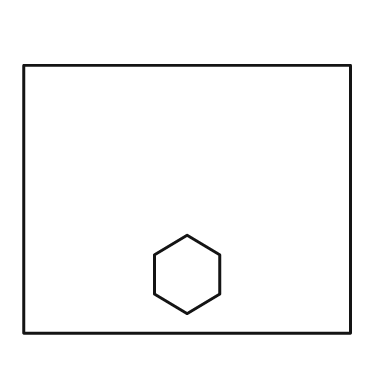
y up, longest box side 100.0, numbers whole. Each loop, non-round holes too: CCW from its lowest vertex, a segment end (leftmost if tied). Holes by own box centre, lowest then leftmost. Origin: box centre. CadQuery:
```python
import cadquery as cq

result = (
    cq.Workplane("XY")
    .moveTo(-50.0, -41.0)
    .lineTo(50.0, -41.0)
    .lineTo(50.0, 41.0)
    .lineTo(-50.0, 41.0)
    .close()
    .moveTo(0.0, -35.0)
    .lineTo(10.0, -29.0)
    .lineTo(10.0, -17.0)
    .lineTo(0.0, -11.0)
    .lineTo(-10.0, -17.0)
    .lineTo(-10.0, -29.0)
    .close()
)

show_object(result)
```